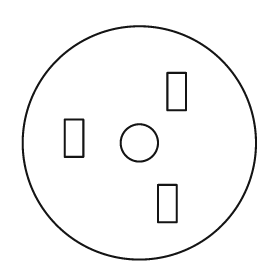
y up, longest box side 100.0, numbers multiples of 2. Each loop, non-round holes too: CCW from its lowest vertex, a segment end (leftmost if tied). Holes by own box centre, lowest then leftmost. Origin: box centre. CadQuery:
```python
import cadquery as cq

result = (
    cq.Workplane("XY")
    .moveTo(0.0, 0.0)
    .circle(50.0)
    .moveTo(8.0, -34.0)
    .lineTo(16.0, -34.0)
    .lineTo(16.0, -18.0)
    .lineTo(8.0, -18.0)
    .close()
    .moveTo(0.0, 0.0)
    .circle(8.0)
    .moveTo(-32.0, -6.0)
    .lineTo(-24.0, -6.0)
    .lineTo(-24.0, 10.0)
    .lineTo(-32.0, 10.0)
    .close()
    .moveTo(12.0, 14.0)
    .lineTo(20.0, 14.0)
    .lineTo(20.0, 30.0)
    .lineTo(12.0, 30.0)
    .close()
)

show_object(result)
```